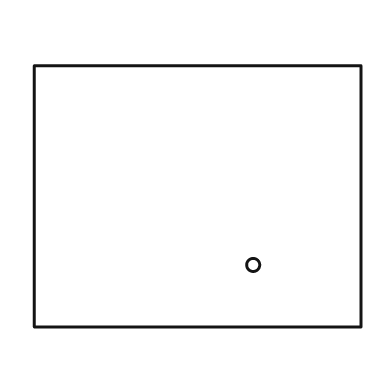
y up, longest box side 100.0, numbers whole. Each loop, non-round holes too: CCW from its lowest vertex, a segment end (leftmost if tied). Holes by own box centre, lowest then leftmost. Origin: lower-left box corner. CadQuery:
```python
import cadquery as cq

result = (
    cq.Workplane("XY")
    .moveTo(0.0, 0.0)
    .lineTo(100.0, 0.0)
    .lineTo(100.0, 80.0)
    .lineTo(0.0, 80.0)
    .close()
    .moveTo(67.0, 19.0)
    .circle(2.0)
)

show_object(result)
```